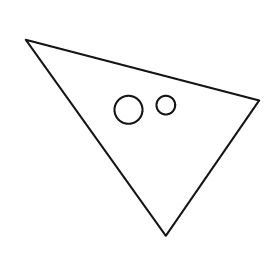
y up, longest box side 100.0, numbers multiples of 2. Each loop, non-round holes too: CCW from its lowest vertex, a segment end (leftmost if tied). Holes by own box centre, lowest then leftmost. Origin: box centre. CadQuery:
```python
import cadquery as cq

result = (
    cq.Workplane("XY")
    .moveTo(10.0, -42.0)
    .lineTo(50.0, 16.0)
    .lineTo(-50.0, 42.0)
    .close()
    .moveTo(-6.0, 12.0)
    .circle(6.0)
    .moveTo(10.0, 14.0)
    .circle(4.0)
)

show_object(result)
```